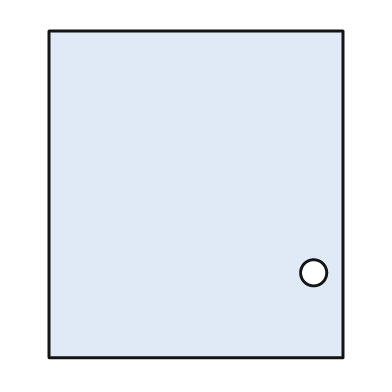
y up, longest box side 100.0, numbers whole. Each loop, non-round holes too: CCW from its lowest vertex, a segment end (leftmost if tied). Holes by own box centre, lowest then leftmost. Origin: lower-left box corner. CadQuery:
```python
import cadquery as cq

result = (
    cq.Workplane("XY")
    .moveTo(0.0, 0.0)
    .lineTo(90.0, 0.0)
    .lineTo(90.0, 100.0)
    .lineTo(0.0, 100.0)
    .close()
    .moveTo(81.0, 26.0)
    .circle(4.0)
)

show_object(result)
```